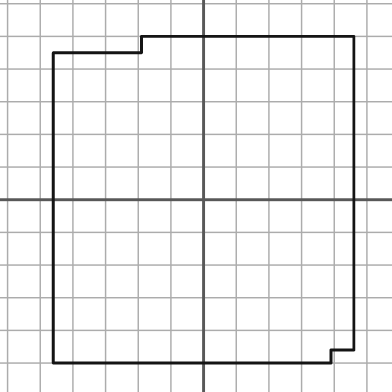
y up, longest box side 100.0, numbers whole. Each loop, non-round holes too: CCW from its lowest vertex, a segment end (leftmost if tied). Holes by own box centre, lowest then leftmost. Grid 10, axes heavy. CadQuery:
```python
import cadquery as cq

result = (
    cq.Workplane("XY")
    .moveTo(-46.0, -50.0)
    .lineTo(39.0, -50.0)
    .lineTo(39.0, -46.0)
    .lineTo(46.0, -46.0)
    .lineTo(46.0, 50.0)
    .lineTo(-19.0, 50.0)
    .lineTo(-19.0, 45.0)
    .lineTo(-46.0, 45.0)
    .close()
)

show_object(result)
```